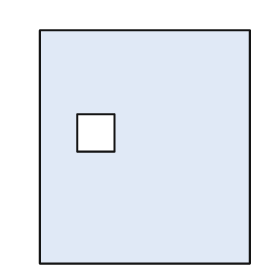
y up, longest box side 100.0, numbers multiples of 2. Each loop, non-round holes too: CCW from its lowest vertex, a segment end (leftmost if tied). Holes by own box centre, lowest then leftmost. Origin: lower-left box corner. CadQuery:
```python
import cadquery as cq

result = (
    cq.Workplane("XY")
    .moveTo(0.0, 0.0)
    .lineTo(90.0, 0.0)
    .lineTo(90.0, 100.0)
    .lineTo(0.0, 100.0)
    .close()
    .moveTo(16.0, 48.0)
    .lineTo(32.0, 48.0)
    .lineTo(32.0, 64.0)
    .lineTo(16.0, 64.0)
    .close()
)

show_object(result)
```